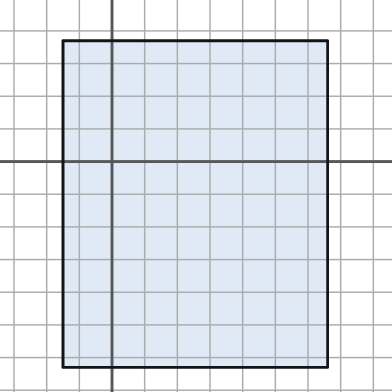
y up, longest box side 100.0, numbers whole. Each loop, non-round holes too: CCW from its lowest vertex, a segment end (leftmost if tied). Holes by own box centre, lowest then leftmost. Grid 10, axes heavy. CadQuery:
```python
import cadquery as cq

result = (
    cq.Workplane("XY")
    .moveTo(-15.0, -63.0)
    .lineTo(66.0, -63.0)
    .lineTo(66.0, 37.0)
    .lineTo(-15.0, 37.0)
    .close()
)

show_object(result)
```